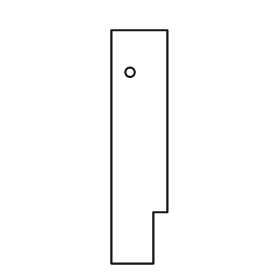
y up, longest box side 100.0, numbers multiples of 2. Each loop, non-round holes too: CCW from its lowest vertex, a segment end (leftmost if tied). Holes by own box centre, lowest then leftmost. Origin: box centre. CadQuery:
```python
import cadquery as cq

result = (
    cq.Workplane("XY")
    .moveTo(-12.0, -50.0)
    .lineTo(6.0, -50.0)
    .lineTo(6.0, -28.0)
    .lineTo(12.0, -28.0)
    .lineTo(12.0, 50.0)
    .lineTo(-12.0, 50.0)
    .close()
    .moveTo(-4.0, 32.0)
    .circle(2.0)
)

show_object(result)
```